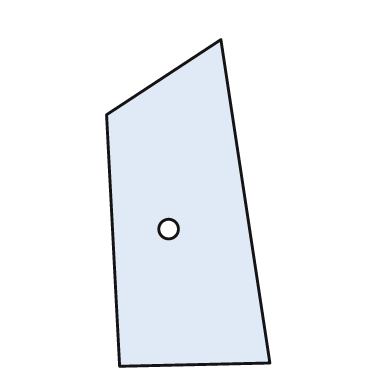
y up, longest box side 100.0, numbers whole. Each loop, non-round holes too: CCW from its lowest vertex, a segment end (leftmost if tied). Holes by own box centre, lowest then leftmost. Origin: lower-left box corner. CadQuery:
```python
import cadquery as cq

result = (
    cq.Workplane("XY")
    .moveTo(4.0, 0.0)
    .lineTo(50.0, 1.0)
    .lineTo(35.0, 100.0)
    .lineTo(0.0, 77.0)
    .close()
    .moveTo(19.0, 42.0)
    .circle(3.0)
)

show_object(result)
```